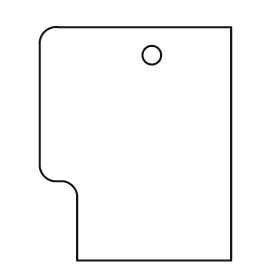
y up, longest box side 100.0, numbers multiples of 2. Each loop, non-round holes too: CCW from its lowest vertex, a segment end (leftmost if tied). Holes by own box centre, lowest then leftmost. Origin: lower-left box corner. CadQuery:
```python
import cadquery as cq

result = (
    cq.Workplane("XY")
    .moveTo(16.0, 0.0)
    .lineTo(82.0, 0.0)
    .lineTo(82.0, 100.0)
    .lineTo(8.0, 100.0)
    .threePointArc((2.0, 98.0), (0.0, 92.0))
    .lineTo(0.0, 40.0)
    .threePointArc((2.0, 36.0), (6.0, 34.0))
    .lineTo(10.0, 34.0)
    .threePointArc((14.0, 32.0), (16.0, 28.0))
    .close()
    .moveTo(48.0, 88.0)
    .circle(4.0)
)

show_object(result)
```